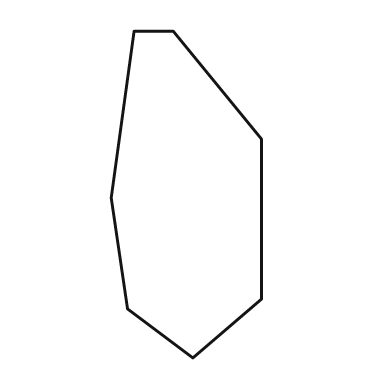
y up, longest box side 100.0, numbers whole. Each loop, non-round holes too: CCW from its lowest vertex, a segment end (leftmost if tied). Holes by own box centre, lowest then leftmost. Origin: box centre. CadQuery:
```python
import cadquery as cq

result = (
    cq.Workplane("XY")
    .moveTo(2.0, -50.0)
    .lineTo(23.0, -32.0)
    .lineTo(23.0, 17.0)
    .lineTo(-4.0, 50.0)
    .lineTo(-16.0, 50.0)
    .lineTo(-23.0, -1.0)
    .lineTo(-18.0, -35.0)
    .close()
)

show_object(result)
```